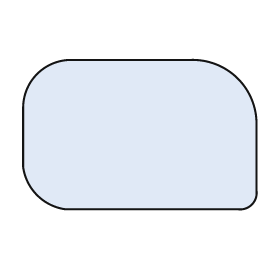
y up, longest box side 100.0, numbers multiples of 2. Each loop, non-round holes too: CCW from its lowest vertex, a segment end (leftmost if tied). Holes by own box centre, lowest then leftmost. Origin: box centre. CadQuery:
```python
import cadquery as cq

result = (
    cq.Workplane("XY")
    .moveTo(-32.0, -32.0)
    .lineTo(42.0, -32.0)
    .threePointArc((48.0, -30.0), (50.0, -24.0))
    .lineTo(50.0, 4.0)
    .threePointArc((42.0, 24.0), (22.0, 32.0))
    .lineTo(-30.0, 32.0)
    .threePointArc((-44.0, 26.0), (-50.0, 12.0))
    .lineTo(-50.0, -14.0)
    .threePointArc((-44.0, -26.0), (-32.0, -32.0))
    .close()
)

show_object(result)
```